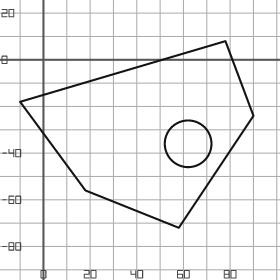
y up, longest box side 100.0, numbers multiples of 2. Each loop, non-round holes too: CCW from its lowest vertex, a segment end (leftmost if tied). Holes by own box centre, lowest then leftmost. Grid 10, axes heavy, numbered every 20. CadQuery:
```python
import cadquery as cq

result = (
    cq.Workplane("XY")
    .moveTo(58.0, -72.0)
    .lineTo(90.0, -24.0)
    .lineTo(78.0, 8.0)
    .lineTo(-10.0, -18.0)
    .lineTo(18.0, -56.0)
    .close()
    .moveTo(62.0, -36.0)
    .circle(10.0)
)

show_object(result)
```